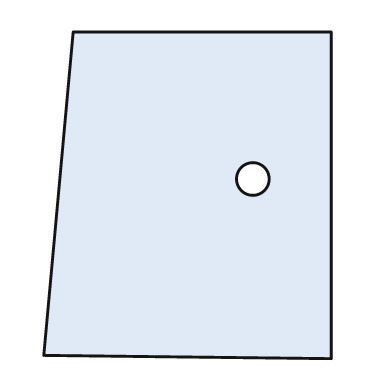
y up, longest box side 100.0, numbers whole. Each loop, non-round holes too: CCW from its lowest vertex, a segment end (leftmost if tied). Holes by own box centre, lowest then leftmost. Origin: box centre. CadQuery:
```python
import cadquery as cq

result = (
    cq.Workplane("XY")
    .moveTo(44.0, -50.0)
    .lineTo(44.0, 50.0)
    .lineTo(-35.0, 50.0)
    .lineTo(-44.0, -49.0)
    .close()
    .moveTo(20.0, 5.0)
    .circle(5.0)
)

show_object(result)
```